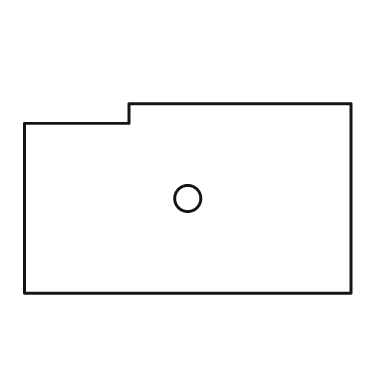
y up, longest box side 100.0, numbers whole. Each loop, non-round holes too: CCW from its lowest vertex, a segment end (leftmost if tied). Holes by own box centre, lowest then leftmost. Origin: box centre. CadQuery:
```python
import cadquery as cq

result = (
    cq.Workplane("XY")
    .moveTo(-50.0, -29.0)
    .lineTo(50.0, -29.0)
    .lineTo(50.0, 29.0)
    .lineTo(-18.0, 29.0)
    .lineTo(-18.0, 23.0)
    .lineTo(-50.0, 23.0)
    .close()
    .moveTo(0.0, 0.0)
    .circle(4.0)
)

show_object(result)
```